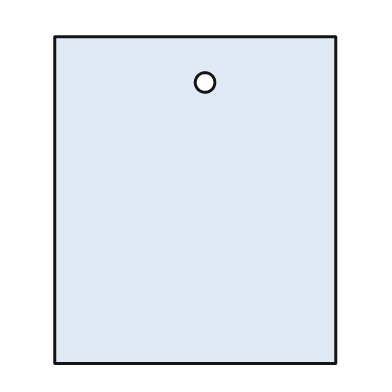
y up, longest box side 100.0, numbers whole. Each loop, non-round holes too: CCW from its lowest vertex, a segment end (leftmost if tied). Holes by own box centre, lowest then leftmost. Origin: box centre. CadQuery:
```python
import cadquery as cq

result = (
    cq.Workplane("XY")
    .moveTo(-43.0, -50.0)
    .lineTo(43.0, -50.0)
    .lineTo(43.0, 50.0)
    .lineTo(-43.0, 50.0)
    .close()
    .moveTo(3.0, 36.0)
    .circle(3.0)
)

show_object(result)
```